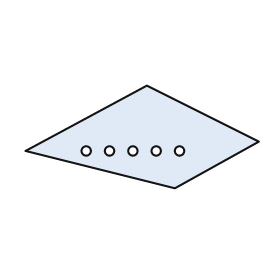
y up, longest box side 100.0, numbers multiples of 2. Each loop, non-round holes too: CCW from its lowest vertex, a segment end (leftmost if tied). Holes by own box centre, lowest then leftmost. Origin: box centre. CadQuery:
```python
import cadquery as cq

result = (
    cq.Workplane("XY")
    .moveTo(14.0, -22.0)
    .lineTo(50.0, -2.0)
    .lineTo(2.0, 22.0)
    .lineTo(-50.0, -6.0)
    .close()
    .moveTo(-24.0, -6.0)
    .circle(2.0)
    .moveTo(-14.0, -6.0)
    .circle(2.0)
    .moveTo(-4.0, -6.0)
    .circle(2.0)
    .moveTo(6.0, -6.0)
    .circle(2.0)
    .moveTo(16.0, -6.0)
    .circle(2.0)
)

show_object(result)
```